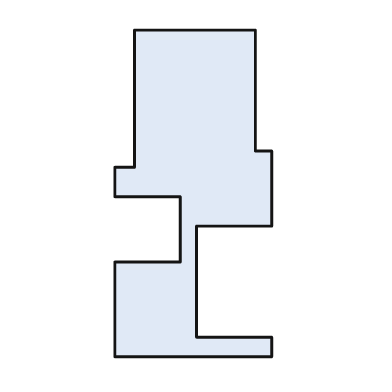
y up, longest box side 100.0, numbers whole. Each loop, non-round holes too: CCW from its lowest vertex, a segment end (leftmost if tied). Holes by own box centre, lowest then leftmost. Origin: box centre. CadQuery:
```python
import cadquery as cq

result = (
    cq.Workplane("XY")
    .moveTo(-24.0, -50.0)
    .lineTo(24.0, -50.0)
    .lineTo(24.0, -44.0)
    .lineTo(1.0, -44.0)
    .lineTo(1.0, -10.0)
    .lineTo(24.0, -10.0)
    .lineTo(24.0, 13.0)
    .lineTo(19.0, 13.0)
    .lineTo(19.0, 50.0)
    .lineTo(-18.0, 50.0)
    .lineTo(-18.0, 8.0)
    .lineTo(-24.0, 8.0)
    .lineTo(-24.0, -1.0)
    .lineTo(-4.0, -1.0)
    .lineTo(-4.0, -21.0)
    .lineTo(-24.0, -21.0)
    .close()
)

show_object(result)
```